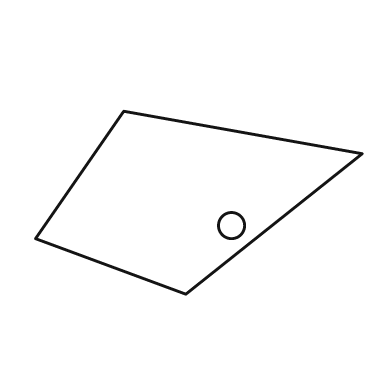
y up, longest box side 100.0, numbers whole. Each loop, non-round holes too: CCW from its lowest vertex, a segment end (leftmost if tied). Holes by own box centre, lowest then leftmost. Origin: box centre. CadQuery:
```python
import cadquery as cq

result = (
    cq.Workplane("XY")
    .moveTo(-4.0, -28.0)
    .lineTo(50.0, 15.0)
    .lineTo(-23.0, 28.0)
    .lineTo(-50.0, -11.0)
    .close()
    .moveTo(10.0, -7.0)
    .circle(4.0)
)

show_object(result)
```